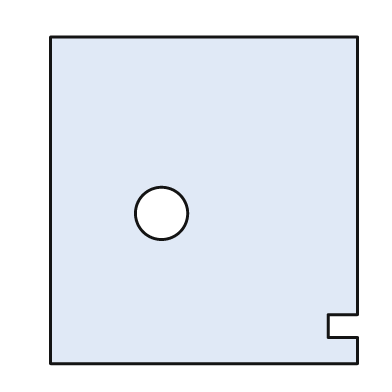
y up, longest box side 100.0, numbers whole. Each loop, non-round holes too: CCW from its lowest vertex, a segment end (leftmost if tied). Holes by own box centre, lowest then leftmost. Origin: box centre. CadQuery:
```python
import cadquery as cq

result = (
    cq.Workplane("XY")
    .moveTo(-47.0, -50.0)
    .lineTo(47.0, -50.0)
    .lineTo(47.0, -42.0)
    .lineTo(38.0, -42.0)
    .lineTo(38.0, -35.0)
    .lineTo(47.0, -35.0)
    .lineTo(47.0, 50.0)
    .lineTo(-47.0, 50.0)
    .close()
    .moveTo(-13.0, -4.0)
    .circle(8.0)
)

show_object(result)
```